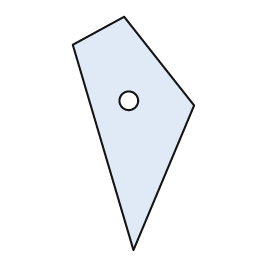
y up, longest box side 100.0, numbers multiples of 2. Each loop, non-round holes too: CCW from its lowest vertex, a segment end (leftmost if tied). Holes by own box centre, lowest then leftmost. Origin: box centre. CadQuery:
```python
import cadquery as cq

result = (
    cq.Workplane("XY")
    .moveTo(0.0, -50.0)
    .lineTo(26.0, 12.0)
    .lineTo(-4.0, 50.0)
    .lineTo(-26.0, 38.0)
    .close()
    .moveTo(-2.0, 14.0)
    .circle(4.0)
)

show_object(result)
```